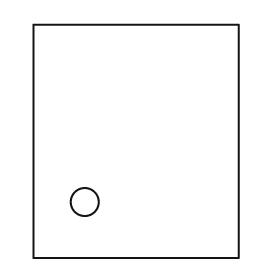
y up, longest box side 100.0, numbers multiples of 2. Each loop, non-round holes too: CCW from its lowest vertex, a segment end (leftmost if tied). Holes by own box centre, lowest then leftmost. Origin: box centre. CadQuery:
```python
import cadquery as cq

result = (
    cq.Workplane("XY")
    .moveTo(-44.0, -50.0)
    .lineTo(44.0, -50.0)
    .lineTo(44.0, 50.0)
    .lineTo(-44.0, 50.0)
    .close()
    .moveTo(-22.0, -26.0)
    .circle(6.0)
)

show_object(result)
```